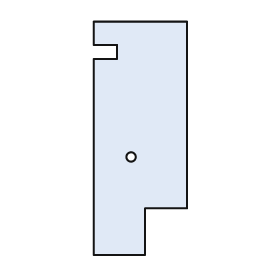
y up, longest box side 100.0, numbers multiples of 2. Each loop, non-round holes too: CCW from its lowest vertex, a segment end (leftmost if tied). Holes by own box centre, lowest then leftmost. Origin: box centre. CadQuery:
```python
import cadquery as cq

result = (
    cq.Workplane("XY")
    .moveTo(-20.0, -50.0)
    .lineTo(2.0, -50.0)
    .lineTo(2.0, -30.0)
    .lineTo(20.0, -30.0)
    .lineTo(20.0, 50.0)
    .lineTo(-20.0, 50.0)
    .lineTo(-20.0, 40.0)
    .lineTo(-10.0, 40.0)
    .lineTo(-10.0, 34.0)
    .lineTo(-20.0, 34.0)
    .close()
    .moveTo(-4.0, -8.0)
    .circle(2.0)
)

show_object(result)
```